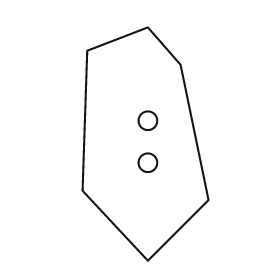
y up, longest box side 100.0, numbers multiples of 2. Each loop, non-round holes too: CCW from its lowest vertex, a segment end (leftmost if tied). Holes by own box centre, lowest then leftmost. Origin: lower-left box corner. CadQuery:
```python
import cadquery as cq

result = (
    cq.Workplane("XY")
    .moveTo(28.0, 0.0)
    .lineTo(54.0, 26.0)
    .lineTo(42.0, 84.0)
    .lineTo(28.0, 100.0)
    .lineTo(2.0, 90.0)
    .lineTo(0.0, 30.0)
    .close()
    .moveTo(28.0, 42.0)
    .circle(4.0)
    .moveTo(28.0, 60.0)
    .circle(4.0)
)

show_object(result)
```